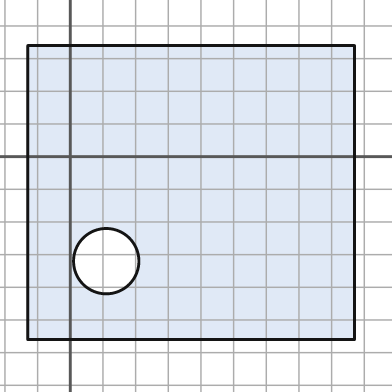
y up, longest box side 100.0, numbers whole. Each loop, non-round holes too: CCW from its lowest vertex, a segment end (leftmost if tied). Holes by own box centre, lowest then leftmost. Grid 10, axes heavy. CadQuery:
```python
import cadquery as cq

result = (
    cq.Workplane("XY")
    .moveTo(-13.0, -56.0)
    .lineTo(87.0, -56.0)
    .lineTo(87.0, 34.0)
    .lineTo(-13.0, 34.0)
    .close()
    .moveTo(11.0, -32.0)
    .circle(10.0)
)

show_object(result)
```